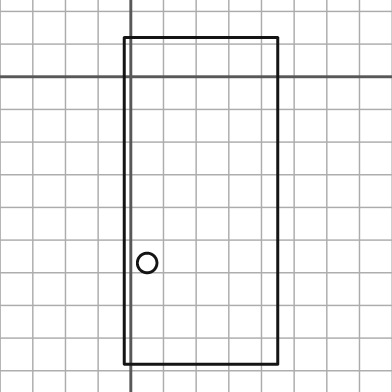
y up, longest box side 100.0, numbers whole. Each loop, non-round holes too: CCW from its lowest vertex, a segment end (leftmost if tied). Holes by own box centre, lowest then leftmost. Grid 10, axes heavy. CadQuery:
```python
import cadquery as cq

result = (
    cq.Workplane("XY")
    .moveTo(-2.0, -88.0)
    .lineTo(45.0, -88.0)
    .lineTo(45.0, 12.0)
    .lineTo(-2.0, 12.0)
    .close()
    .moveTo(5.0, -57.0)
    .circle(3.0)
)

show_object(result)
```